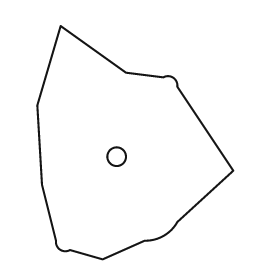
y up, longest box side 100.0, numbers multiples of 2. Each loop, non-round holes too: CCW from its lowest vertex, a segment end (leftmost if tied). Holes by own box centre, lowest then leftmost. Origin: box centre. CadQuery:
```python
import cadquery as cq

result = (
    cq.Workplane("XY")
    .moveTo(-14.0, -50.0)
    .lineTo(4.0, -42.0)
    .threePointArc((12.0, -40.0), (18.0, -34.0))
    .lineTo(42.0, -12.0)
    .lineTo(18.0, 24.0)
    .threePointArc((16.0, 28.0), (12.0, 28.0))
    .lineTo(-4.0, 30.0)
    .lineTo(-32.0, 50.0)
    .lineTo(-42.0, 16.0)
    .lineTo(-40.0, -18.0)
    .lineTo(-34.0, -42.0)
    .threePointArc((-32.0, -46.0), (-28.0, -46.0))
    .close()
    .moveTo(-8.0, -6.0)
    .circle(4.0)
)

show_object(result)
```